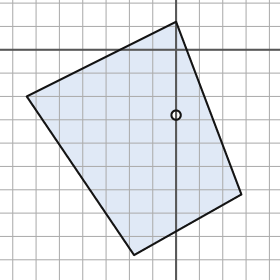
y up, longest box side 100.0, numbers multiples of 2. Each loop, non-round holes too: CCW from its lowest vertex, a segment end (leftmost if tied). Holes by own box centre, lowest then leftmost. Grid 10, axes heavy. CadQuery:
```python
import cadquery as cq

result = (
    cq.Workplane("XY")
    .moveTo(-18.0, -88.0)
    .lineTo(28.0, -62.0)
    .lineTo(0.0, 12.0)
    .lineTo(-64.0, -20.0)
    .close()
    .moveTo(0.0, -28.0)
    .circle(2.0)
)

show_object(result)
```